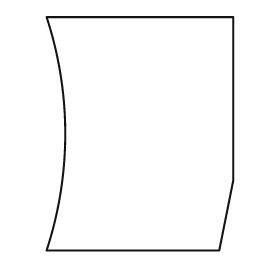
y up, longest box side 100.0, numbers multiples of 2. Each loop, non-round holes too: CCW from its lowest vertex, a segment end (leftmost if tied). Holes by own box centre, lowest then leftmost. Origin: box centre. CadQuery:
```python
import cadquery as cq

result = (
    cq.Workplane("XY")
    .moveTo(-40.0, -50.0)
    .lineTo(34.0, -50.0)
    .lineTo(40.0, -20.0)
    .lineTo(40.0, 50.0)
    .lineTo(-40.0, 50.0)
    .threePointArc((-32.0, 0.0), (-40.0, -50.0))
    .close()
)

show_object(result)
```